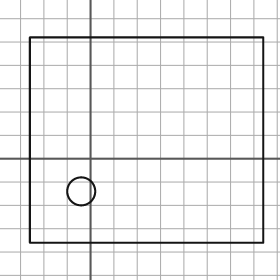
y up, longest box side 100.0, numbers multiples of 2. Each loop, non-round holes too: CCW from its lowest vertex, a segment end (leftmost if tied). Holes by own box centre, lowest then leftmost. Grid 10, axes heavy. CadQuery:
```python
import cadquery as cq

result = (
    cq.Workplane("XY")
    .moveTo(-26.0, -36.0)
    .lineTo(74.0, -36.0)
    .lineTo(74.0, 52.0)
    .lineTo(-26.0, 52.0)
    .close()
    .moveTo(-4.0, -14.0)
    .circle(6.0)
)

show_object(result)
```